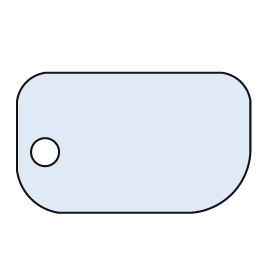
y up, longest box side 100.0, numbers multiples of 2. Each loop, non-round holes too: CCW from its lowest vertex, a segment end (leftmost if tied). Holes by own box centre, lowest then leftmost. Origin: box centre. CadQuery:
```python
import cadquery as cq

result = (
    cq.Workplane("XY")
    .moveTo(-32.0, -30.0)
    .lineTo(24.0, -30.0)
    .threePointArc((42.0, -22.0), (50.0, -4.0))
    .lineTo(50.0, 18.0)
    .threePointArc((46.0, 26.0), (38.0, 30.0))
    .lineTo(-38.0, 30.0)
    .threePointArc((-46.0, 26.0), (-50.0, 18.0))
    .lineTo(-50.0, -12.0)
    .threePointArc((-44.0, -24.0), (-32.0, -30.0))
    .close()
    .moveTo(-38.0, -4.0)
    .circle(6.0)
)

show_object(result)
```